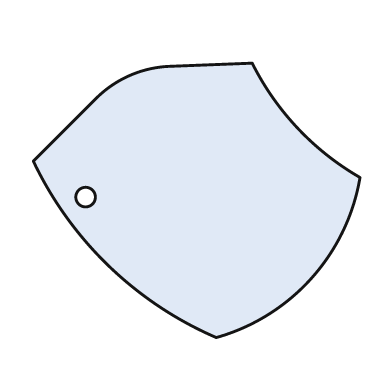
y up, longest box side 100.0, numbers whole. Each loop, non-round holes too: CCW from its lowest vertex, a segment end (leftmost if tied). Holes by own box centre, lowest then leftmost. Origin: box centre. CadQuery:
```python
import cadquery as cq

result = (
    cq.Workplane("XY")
    .moveTo(6.0, -42.0)
    .threePointArc((35.0, -24.0), (50.0, 7.0))
    .threePointArc((31.0, 22.0), (17.0, 42.0))
    .lineTo(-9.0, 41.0)
    .threePointArc((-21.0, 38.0), (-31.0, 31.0))
    .lineTo(-50.0, 12.0)
    .threePointArc((-27.0, -20.0), (6.0, -42.0))
    .close()
    .moveTo(-34.0, 1.0)
    .circle(3.0)
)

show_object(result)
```